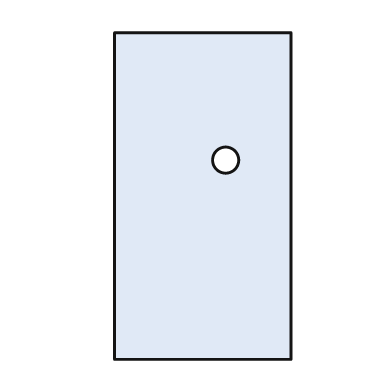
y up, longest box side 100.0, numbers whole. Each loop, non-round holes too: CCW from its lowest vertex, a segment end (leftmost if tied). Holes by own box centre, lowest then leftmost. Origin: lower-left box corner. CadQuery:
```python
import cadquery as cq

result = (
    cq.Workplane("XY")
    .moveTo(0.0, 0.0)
    .lineTo(54.0, 0.0)
    .lineTo(54.0, 100.0)
    .lineTo(0.0, 100.0)
    .close()
    .moveTo(34.0, 61.0)
    .circle(4.0)
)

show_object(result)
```